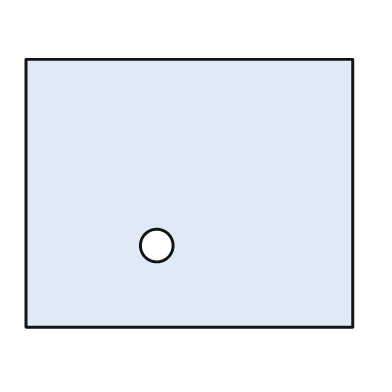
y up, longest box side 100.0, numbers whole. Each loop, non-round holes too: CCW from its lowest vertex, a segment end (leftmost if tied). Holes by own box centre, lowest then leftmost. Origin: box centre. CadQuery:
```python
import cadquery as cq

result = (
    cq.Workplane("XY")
    .moveTo(-50.0, -41.0)
    .lineTo(50.0, -41.0)
    .lineTo(50.0, 41.0)
    .lineTo(-50.0, 41.0)
    .close()
    .moveTo(-10.0, -16.0)
    .circle(5.0)
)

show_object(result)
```